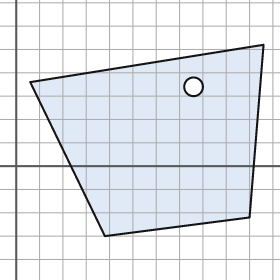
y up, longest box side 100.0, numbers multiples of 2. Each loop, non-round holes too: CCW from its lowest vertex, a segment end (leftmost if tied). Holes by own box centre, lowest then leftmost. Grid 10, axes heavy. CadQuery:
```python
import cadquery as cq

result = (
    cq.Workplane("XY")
    .moveTo(38.0, -30.0)
    .lineTo(100.0, -22.0)
    .lineTo(106.0, 52.0)
    .lineTo(6.0, 36.0)
    .close()
    .moveTo(76.0, 34.0)
    .circle(4.0)
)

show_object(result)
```